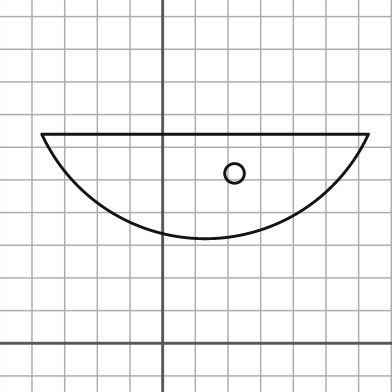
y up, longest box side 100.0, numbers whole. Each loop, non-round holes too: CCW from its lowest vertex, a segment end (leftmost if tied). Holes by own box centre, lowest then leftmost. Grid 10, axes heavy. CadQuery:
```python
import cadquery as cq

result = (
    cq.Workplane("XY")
    .moveTo(-37.0, 64.0)
    .threePointArc((13.0, 32.0), (63.0, 64.0))
    .close()
    .moveTo(22.0, 52.0)
    .circle(3.0)
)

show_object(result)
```